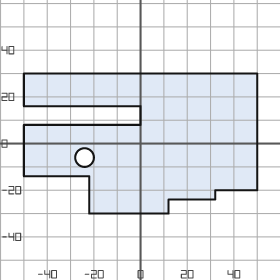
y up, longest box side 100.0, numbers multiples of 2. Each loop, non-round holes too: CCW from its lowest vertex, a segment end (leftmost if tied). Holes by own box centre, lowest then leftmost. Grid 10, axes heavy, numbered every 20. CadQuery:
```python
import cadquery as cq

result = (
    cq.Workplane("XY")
    .moveTo(-22.0, -30.0)
    .lineTo(12.0, -30.0)
    .lineTo(12.0, -24.0)
    .lineTo(32.0, -24.0)
    .lineTo(32.0, -20.0)
    .lineTo(50.0, -20.0)
    .lineTo(50.0, 30.0)
    .lineTo(-50.0, 30.0)
    .lineTo(-50.0, 16.0)
    .lineTo(0.0, 16.0)
    .lineTo(0.0, 8.0)
    .lineTo(-50.0, 8.0)
    .lineTo(-50.0, -14.0)
    .lineTo(-22.0, -14.0)
    .close()
    .moveTo(-24.0, -6.0)
    .circle(4.0)
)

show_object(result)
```